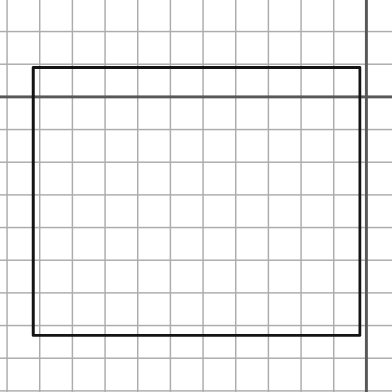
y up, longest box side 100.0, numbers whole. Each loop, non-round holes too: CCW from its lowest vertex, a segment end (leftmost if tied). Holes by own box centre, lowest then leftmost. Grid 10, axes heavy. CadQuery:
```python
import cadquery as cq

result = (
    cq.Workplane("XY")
    .moveTo(-102.0, -73.0)
    .lineTo(-2.0, -73.0)
    .lineTo(-2.0, 9.0)
    .lineTo(-102.0, 9.0)
    .close()
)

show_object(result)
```